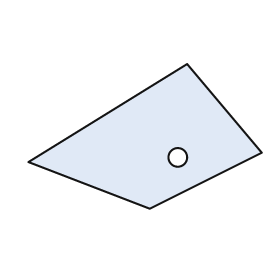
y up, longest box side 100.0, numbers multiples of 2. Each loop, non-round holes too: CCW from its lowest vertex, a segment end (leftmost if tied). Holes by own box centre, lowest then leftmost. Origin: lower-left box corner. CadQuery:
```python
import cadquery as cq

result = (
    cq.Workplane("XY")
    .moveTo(52.0, 0.0)
    .lineTo(100.0, 24.0)
    .lineTo(68.0, 62.0)
    .lineTo(0.0, 20.0)
    .close()
    .moveTo(64.0, 22.0)
    .circle(4.0)
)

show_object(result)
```